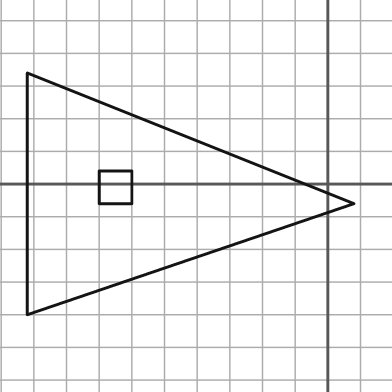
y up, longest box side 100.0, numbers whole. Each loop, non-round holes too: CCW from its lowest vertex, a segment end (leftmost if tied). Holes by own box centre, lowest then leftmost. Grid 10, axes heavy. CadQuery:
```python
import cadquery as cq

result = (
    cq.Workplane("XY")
    .moveTo(-92.0, -40.0)
    .lineTo(8.0, -6.0)
    .lineTo(-92.0, 34.0)
    .close()
    .moveTo(-70.0, -6.0)
    .lineTo(-60.0, -6.0)
    .lineTo(-60.0, 4.0)
    .lineTo(-70.0, 4.0)
    .close()
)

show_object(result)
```